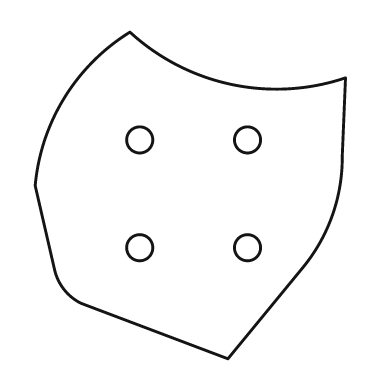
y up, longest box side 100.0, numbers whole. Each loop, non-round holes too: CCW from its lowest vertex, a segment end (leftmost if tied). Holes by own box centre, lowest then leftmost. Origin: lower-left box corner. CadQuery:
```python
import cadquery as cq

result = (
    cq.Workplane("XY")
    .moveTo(59.0, 0.0)
    .lineTo(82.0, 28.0)
    .threePointArc((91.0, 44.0), (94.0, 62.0))
    .lineTo(95.0, 86.0)
    .threePointArc((60.0, 84.0), (29.0, 100.0))
    .threePointArc((9.0, 80.0), (0.0, 53.0))
    .lineTo(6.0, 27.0)
    .threePointArc((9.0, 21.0), (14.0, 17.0))
    .close()
    .moveTo(32.0, 34.0)
    .circle(4.0)
    .moveTo(65.0, 34.0)
    .circle(4.0)
    .moveTo(32.0, 67.0)
    .circle(4.0)
    .moveTo(65.0, 67.0)
    .circle(4.0)
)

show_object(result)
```